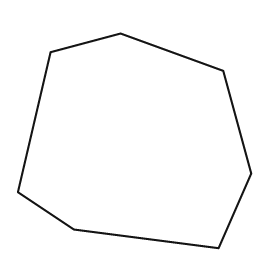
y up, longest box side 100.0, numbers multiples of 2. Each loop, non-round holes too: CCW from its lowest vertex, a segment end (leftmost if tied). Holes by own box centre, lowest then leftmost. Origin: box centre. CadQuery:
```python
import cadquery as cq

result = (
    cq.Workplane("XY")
    .moveTo(36.0, -46.0)
    .lineTo(50.0, -14.0)
    .lineTo(38.0, 30.0)
    .lineTo(-6.0, 46.0)
    .lineTo(-36.0, 38.0)
    .lineTo(-50.0, -22.0)
    .lineTo(-26.0, -38.0)
    .close()
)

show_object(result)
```